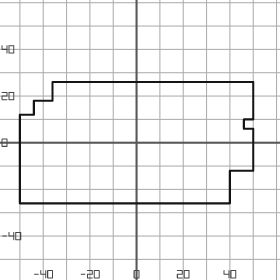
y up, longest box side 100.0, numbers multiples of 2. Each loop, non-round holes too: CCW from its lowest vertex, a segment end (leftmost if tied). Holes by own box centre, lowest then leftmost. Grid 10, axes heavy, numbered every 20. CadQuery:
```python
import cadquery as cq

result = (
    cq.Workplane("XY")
    .moveTo(-50.0, -26.0)
    .lineTo(40.0, -26.0)
    .lineTo(40.0, -12.0)
    .lineTo(50.0, -12.0)
    .lineTo(50.0, 6.0)
    .lineTo(46.0, 6.0)
    .lineTo(46.0, 10.0)
    .lineTo(50.0, 10.0)
    .lineTo(50.0, 26.0)
    .lineTo(-36.0, 26.0)
    .lineTo(-36.0, 18.0)
    .lineTo(-44.0, 18.0)
    .lineTo(-44.0, 12.0)
    .lineTo(-50.0, 12.0)
    .close()
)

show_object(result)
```